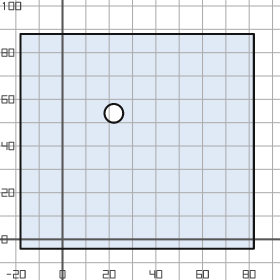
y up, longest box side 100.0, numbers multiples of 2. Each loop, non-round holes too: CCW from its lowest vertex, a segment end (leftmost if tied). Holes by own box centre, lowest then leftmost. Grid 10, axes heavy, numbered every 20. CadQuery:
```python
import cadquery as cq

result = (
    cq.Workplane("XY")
    .moveTo(-18.0, -4.0)
    .lineTo(82.0, -4.0)
    .lineTo(82.0, 88.0)
    .lineTo(-18.0, 88.0)
    .close()
    .moveTo(22.0, 54.0)
    .circle(4.0)
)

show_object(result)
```